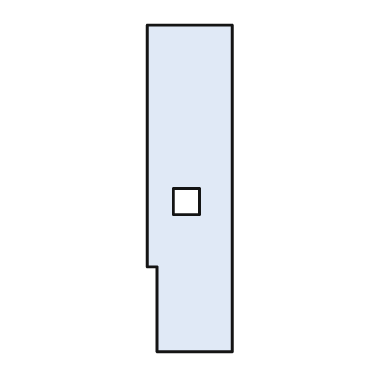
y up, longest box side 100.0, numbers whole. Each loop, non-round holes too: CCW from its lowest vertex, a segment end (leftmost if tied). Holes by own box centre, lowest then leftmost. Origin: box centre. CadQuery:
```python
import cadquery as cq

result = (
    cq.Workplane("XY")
    .moveTo(-10.0, -50.0)
    .lineTo(13.0, -50.0)
    .lineTo(13.0, 50.0)
    .lineTo(-13.0, 50.0)
    .lineTo(-13.0, -24.0)
    .lineTo(-10.0, -24.0)
    .close()
    .moveTo(-5.0, -8.0)
    .lineTo(3.0, -8.0)
    .lineTo(3.0, 0.0)
    .lineTo(-5.0, 0.0)
    .close()
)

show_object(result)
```